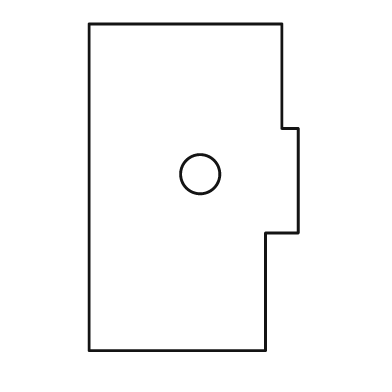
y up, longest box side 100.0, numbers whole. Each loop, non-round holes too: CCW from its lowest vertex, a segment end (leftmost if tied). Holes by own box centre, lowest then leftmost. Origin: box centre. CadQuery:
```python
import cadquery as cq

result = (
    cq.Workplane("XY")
    .moveTo(-32.0, -50.0)
    .lineTo(22.0, -50.0)
    .lineTo(22.0, -14.0)
    .lineTo(32.0, -14.0)
    .lineTo(32.0, 18.0)
    .lineTo(27.0, 18.0)
    .lineTo(27.0, 50.0)
    .lineTo(-32.0, 50.0)
    .close()
    .moveTo(2.0, 4.0)
    .circle(6.0)
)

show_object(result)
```